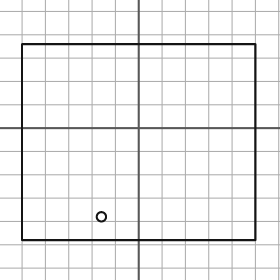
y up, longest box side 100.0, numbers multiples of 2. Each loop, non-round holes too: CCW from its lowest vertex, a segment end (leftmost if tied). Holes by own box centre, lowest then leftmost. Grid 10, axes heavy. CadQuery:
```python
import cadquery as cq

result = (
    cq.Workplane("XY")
    .moveTo(-50.0, -48.0)
    .lineTo(50.0, -48.0)
    .lineTo(50.0, 36.0)
    .lineTo(-50.0, 36.0)
    .close()
    .moveTo(-16.0, -38.0)
    .circle(2.0)
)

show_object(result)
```